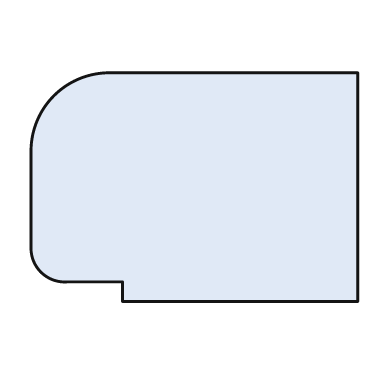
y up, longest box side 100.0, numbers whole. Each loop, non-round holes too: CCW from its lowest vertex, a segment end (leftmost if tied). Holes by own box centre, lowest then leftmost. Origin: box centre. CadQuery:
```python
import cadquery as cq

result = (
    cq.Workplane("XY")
    .moveTo(-22.0, -35.0)
    .lineTo(50.0, -35.0)
    .lineTo(50.0, 35.0)
    .lineTo(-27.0, 35.0)
    .threePointArc((-43.0, 28.0), (-50.0, 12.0))
    .lineTo(-50.0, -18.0)
    .threePointArc((-47.0, -26.0), (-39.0, -29.0))
    .lineTo(-22.0, -29.0)
    .close()
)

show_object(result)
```